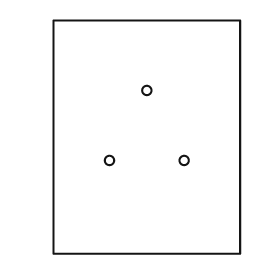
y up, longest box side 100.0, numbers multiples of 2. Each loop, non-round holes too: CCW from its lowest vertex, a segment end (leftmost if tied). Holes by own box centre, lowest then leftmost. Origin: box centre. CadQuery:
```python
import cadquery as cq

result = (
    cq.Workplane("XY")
    .moveTo(-40.0, -50.0)
    .lineTo(40.0, -50.0)
    .lineTo(40.0, 50.0)
    .lineTo(-40.0, 50.0)
    .close()
    .moveTo(-16.0, -10.0)
    .circle(2.0)
    .moveTo(16.0, -10.0)
    .circle(2.0)
    .moveTo(0.0, 20.0)
    .circle(2.0)
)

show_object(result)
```